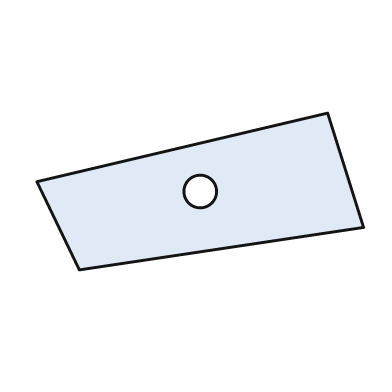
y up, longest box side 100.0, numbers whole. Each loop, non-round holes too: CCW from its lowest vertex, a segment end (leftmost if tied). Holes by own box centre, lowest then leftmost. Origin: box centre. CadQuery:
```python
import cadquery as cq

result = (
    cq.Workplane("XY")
    .moveTo(-37.0, -24.0)
    .lineTo(50.0, -11.0)
    .lineTo(39.0, 24.0)
    .lineTo(-50.0, 3.0)
    .close()
    .moveTo(0.0, 0.0)
    .circle(5.0)
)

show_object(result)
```